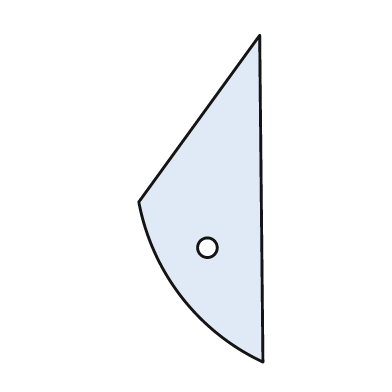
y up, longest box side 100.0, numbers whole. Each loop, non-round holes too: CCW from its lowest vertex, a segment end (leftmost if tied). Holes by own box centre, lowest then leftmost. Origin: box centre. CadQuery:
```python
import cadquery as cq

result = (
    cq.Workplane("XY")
    .moveTo(19.0, -50.0)
    .lineTo(18.0, 50.0)
    .lineTo(-19.0, -1.0)
    .threePointArc((-6.0, -30.0), (19.0, -50.0))
    .close()
    .moveTo(2.0, -15.0)
    .circle(3.0)
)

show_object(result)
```